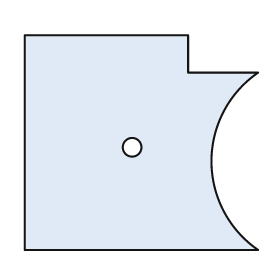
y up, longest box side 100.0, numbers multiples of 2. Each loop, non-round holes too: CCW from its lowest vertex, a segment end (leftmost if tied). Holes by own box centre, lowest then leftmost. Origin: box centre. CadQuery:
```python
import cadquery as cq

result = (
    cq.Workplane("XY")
    .moveTo(-50.0, -46.0)
    .lineTo(50.0, -46.0)
    .threePointArc((30.0, -8.0), (50.0, 30.0))
    .lineTo(20.0, 30.0)
    .lineTo(20.0, 46.0)
    .lineTo(-50.0, 46.0)
    .close()
    .moveTo(-4.0, -2.0)
    .circle(4.0)
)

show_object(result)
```